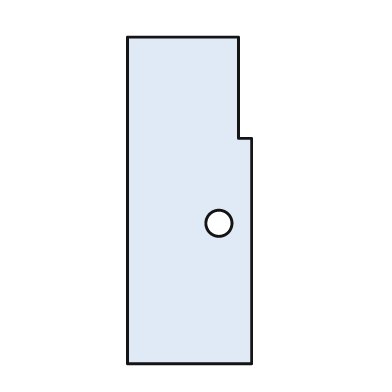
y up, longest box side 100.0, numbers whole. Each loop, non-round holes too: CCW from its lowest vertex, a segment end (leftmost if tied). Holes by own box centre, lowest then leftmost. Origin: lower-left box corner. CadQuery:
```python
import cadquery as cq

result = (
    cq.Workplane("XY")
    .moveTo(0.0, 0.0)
    .lineTo(38.0, 0.0)
    .lineTo(38.0, 69.0)
    .lineTo(34.0, 69.0)
    .lineTo(34.0, 100.0)
    .lineTo(0.0, 100.0)
    .close()
    .moveTo(28.0, 43.0)
    .circle(4.0)
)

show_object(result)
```